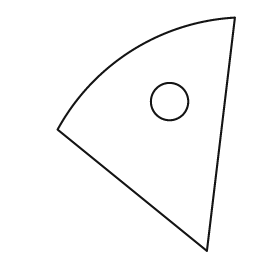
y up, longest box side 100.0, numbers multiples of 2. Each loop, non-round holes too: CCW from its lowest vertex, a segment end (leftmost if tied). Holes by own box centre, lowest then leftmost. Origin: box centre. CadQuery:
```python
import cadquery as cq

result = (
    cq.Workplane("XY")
    .moveTo(26.0, -50.0)
    .lineTo(38.0, 50.0)
    .threePointArc((-6.0, 36.0), (-38.0, 2.0))
    .close()
    .moveTo(10.0, 14.0)
    .circle(8.0)
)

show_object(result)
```